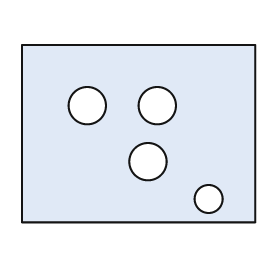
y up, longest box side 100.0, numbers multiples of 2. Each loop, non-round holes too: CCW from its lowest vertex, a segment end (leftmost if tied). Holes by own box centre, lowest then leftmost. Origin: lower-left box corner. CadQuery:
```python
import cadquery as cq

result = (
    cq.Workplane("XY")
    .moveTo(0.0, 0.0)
    .lineTo(100.0, 0.0)
    .lineTo(100.0, 76.0)
    .lineTo(0.0, 76.0)
    .close()
    .moveTo(80.0, 10.0)
    .circle(6.0)
    .moveTo(54.0, 26.0)
    .circle(8.0)
    .moveTo(28.0, 50.0)
    .circle(8.0)
    .moveTo(58.0, 50.0)
    .circle(8.0)
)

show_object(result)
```